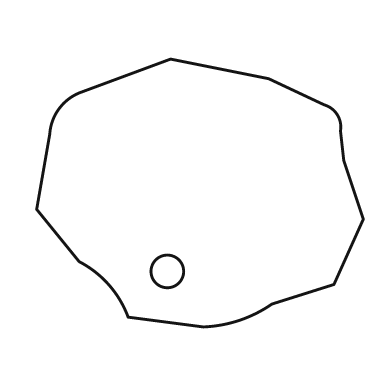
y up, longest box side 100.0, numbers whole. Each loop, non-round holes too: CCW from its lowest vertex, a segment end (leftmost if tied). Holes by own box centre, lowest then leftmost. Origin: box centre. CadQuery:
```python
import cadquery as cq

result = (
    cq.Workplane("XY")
    .moveTo(1.0, -41.0)
    .threePointArc((12.0, -39.0), (22.0, -34.0))
    .lineTo(41.0, -28.0)
    .lineTo(50.0, -8.0)
    .lineTo(44.0, 10.0)
    .lineTo(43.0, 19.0)
    .threePointArc((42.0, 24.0), (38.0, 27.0))
    .lineTo(21.0, 35.0)
    .lineTo(-9.0, 41.0)
    .lineTo(-36.0, 31.0)
    .threePointArc((-43.0, 26.0), (-46.0, 18.0))
    .lineTo(-50.0, -5.0)
    .lineTo(-37.0, -21.0)
    .threePointArc((-28.0, -28.0), (-22.0, -38.0))
    .close()
    .moveTo(-10.0, -24.0)
    .circle(5.0)
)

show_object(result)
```